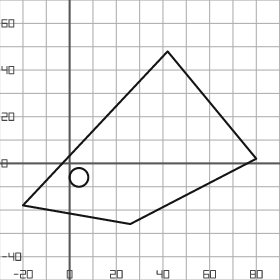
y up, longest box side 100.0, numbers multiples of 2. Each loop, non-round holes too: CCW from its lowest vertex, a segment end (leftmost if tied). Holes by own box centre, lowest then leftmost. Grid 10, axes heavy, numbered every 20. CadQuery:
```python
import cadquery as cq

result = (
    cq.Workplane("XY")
    .moveTo(26.0, -26.0)
    .lineTo(80.0, 2.0)
    .lineTo(42.0, 48.0)
    .lineTo(-20.0, -18.0)
    .close()
    .moveTo(4.0, -6.0)
    .circle(4.0)
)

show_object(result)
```